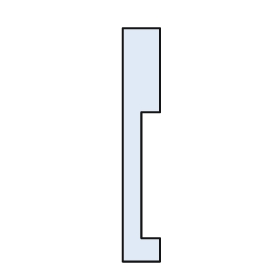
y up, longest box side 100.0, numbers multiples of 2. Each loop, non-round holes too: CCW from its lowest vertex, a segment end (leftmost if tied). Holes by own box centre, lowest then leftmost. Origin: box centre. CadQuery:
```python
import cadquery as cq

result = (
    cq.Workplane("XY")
    .moveTo(-8.0, -50.0)
    .lineTo(8.0, -50.0)
    .lineTo(8.0, -40.0)
    .lineTo(0.0, -40.0)
    .lineTo(0.0, 14.0)
    .lineTo(8.0, 14.0)
    .lineTo(8.0, 50.0)
    .lineTo(-8.0, 50.0)
    .close()
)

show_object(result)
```